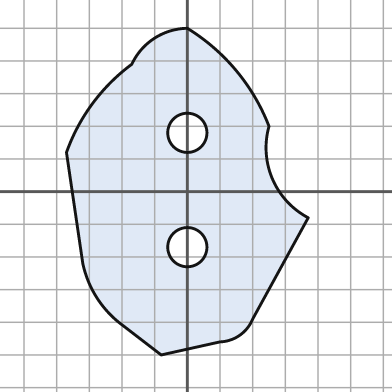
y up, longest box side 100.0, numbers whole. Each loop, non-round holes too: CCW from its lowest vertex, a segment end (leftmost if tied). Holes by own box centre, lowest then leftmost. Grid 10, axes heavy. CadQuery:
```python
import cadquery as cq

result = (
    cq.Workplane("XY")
    .moveTo(-8.0, -50.0)
    .lineTo(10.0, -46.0)
    .threePointArc((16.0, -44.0), (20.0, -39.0))
    .lineTo(37.0, -8.0)
    .threePointArc((26.0, 4.0), (25.0, 20.0))
    .threePointArc((15.0, 37.0), (0.0, 50.0))
    .threePointArc((-10.0, 47.0), (-17.0, 39.0))
    .threePointArc((-29.0, 27.0), (-37.0, 12.0))
    .lineTo(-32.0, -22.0)
    .threePointArc((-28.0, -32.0), (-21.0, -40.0))
    .close()
    .moveTo(0.0, -17.0)
    .circle(6.0)
    .moveTo(0.0, 18.0)
    .circle(6.0)
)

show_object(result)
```